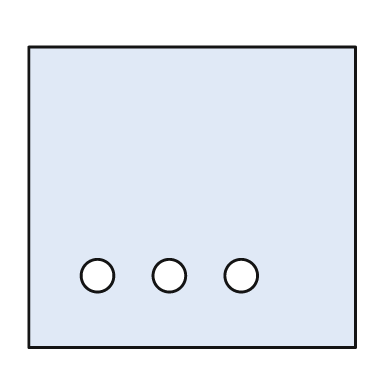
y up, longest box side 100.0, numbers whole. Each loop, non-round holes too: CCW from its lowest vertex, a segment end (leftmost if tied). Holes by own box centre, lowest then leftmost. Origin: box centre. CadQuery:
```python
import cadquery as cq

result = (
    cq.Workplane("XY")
    .moveTo(-50.0, -46.0)
    .lineTo(50.0, -46.0)
    .lineTo(50.0, 46.0)
    .lineTo(-50.0, 46.0)
    .close()
    .moveTo(-29.0, -24.0)
    .circle(5.0)
    .moveTo(-7.0, -24.0)
    .circle(5.0)
    .moveTo(15.0, -24.0)
    .circle(5.0)
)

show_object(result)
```